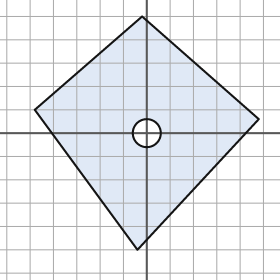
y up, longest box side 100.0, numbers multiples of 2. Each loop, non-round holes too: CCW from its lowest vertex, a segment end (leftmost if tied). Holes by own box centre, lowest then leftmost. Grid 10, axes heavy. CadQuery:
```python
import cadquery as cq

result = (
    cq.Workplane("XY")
    .moveTo(-4.0, -50.0)
    .lineTo(48.0, 6.0)
    .lineTo(-2.0, 50.0)
    .lineTo(-48.0, 10.0)
    .close()
    .moveTo(0.0, 0.0)
    .circle(6.0)
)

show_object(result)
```